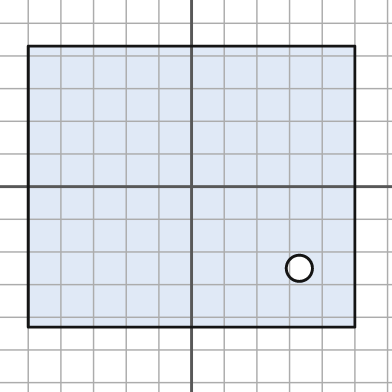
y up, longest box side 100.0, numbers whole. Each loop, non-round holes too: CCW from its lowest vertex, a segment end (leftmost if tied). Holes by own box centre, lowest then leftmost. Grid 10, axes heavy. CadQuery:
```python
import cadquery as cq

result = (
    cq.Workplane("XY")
    .moveTo(-50.0, -43.0)
    .lineTo(50.0, -43.0)
    .lineTo(50.0, 43.0)
    .lineTo(-50.0, 43.0)
    .close()
    .moveTo(33.0, -25.0)
    .circle(4.0)
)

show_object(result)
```